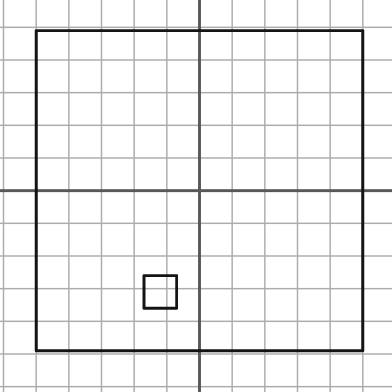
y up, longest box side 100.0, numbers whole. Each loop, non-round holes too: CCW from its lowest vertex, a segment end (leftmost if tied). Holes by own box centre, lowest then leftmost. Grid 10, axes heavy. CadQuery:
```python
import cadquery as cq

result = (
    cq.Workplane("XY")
    .moveTo(-50.0, -49.0)
    .lineTo(50.0, -49.0)
    .lineTo(50.0, 49.0)
    .lineTo(-50.0, 49.0)
    .close()
    .moveTo(-17.0, -36.0)
    .lineTo(-7.0, -36.0)
    .lineTo(-7.0, -26.0)
    .lineTo(-17.0, -26.0)
    .close()
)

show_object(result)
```